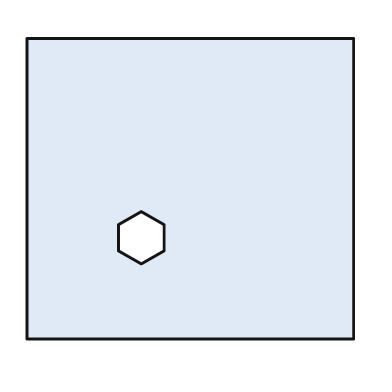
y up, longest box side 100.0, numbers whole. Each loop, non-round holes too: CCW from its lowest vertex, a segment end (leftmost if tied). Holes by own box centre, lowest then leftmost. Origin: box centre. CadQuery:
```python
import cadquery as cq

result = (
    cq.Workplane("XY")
    .moveTo(-50.0, -46.0)
    .lineTo(50.0, -46.0)
    .lineTo(50.0, 46.0)
    .lineTo(-50.0, 46.0)
    .close()
    .moveTo(-15.0, -23.0)
    .lineTo(-8.0, -19.0)
    .lineTo(-8.0, -11.0)
    .lineTo(-15.0, -7.0)
    .lineTo(-22.0, -11.0)
    .lineTo(-22.0, -19.0)
    .close()
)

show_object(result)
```